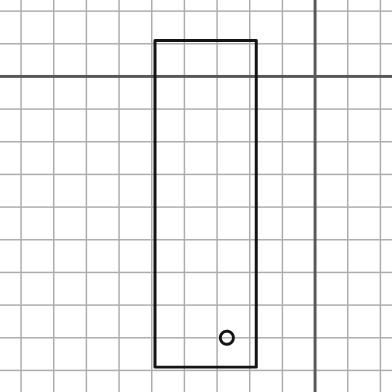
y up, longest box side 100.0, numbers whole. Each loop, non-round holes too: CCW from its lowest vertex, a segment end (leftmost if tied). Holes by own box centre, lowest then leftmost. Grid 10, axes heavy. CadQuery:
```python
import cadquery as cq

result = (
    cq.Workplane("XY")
    .moveTo(-49.0, -89.0)
    .lineTo(-18.0, -89.0)
    .lineTo(-18.0, 11.0)
    .lineTo(-49.0, 11.0)
    .close()
    .moveTo(-27.0, -80.0)
    .circle(2.0)
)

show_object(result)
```